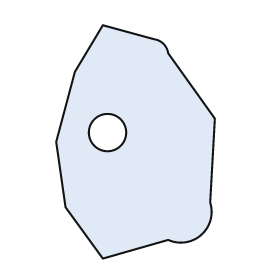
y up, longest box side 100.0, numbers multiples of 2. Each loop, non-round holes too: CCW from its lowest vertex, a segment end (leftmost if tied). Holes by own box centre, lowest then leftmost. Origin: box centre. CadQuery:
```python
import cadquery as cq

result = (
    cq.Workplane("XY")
    .moveTo(-14.0, -50.0)
    .lineTo(14.0, -42.0)
    .threePointArc((28.0, -40.0), (32.0, -26.0))
    .lineTo(34.0, 10.0)
    .lineTo(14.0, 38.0)
    .threePointArc((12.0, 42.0), (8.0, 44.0))
    .lineTo(-14.0, 50.0)
    .lineTo(-26.0, 30.0)
    .lineTo(-34.0, 0.0)
    .lineTo(-30.0, -28.0)
    .close()
    .moveTo(-12.0, 4.0)
    .circle(8.0)
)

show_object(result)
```